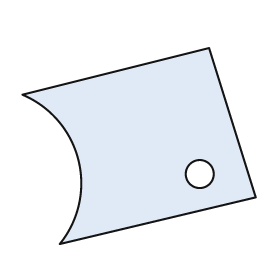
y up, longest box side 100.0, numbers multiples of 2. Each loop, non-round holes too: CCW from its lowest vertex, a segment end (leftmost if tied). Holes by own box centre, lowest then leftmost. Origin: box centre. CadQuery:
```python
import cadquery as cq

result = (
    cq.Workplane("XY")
    .moveTo(-34.0, -42.0)
    .lineTo(50.0, -22.0)
    .lineTo(30.0, 42.0)
    .lineTo(-50.0, 22.0)
    .threePointArc((-26.0, -6.0), (-34.0, -42.0))
    .close()
    .moveTo(26.0, -12.0)
    .circle(6.0)
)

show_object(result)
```